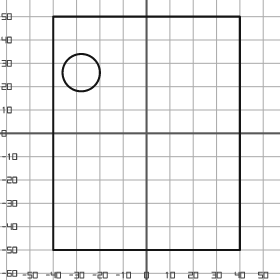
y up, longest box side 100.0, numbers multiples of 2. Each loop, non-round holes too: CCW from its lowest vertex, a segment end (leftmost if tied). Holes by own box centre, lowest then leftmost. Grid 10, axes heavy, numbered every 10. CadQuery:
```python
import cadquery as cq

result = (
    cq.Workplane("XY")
    .moveTo(-40.0, -50.0)
    .lineTo(40.0, -50.0)
    .lineTo(40.0, 50.0)
    .lineTo(-40.0, 50.0)
    .close()
    .moveTo(-28.0, 26.0)
    .circle(8.0)
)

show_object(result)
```